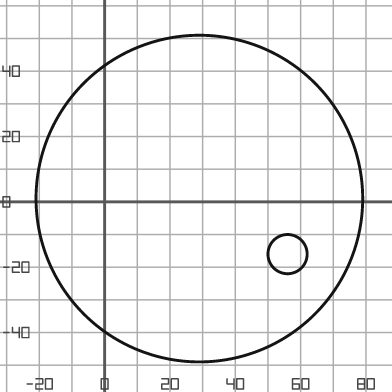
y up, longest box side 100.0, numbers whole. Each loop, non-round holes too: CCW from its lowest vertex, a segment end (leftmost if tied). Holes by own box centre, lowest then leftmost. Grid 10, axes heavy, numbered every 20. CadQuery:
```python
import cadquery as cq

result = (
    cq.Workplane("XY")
    .moveTo(29.0, 1.0)
    .circle(50.0)
    .moveTo(56.0, -16.0)
    .circle(6.0)
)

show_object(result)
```